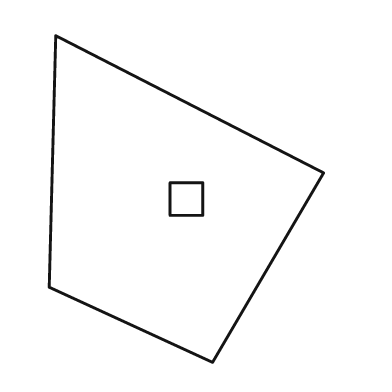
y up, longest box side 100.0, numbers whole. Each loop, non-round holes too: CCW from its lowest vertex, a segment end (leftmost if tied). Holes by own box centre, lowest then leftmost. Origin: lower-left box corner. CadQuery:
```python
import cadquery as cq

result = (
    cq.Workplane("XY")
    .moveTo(50.0, 0.0)
    .lineTo(84.0, 58.0)
    .lineTo(2.0, 100.0)
    .lineTo(0.0, 23.0)
    .close()
    .moveTo(37.0, 45.0)
    .lineTo(47.0, 45.0)
    .lineTo(47.0, 55.0)
    .lineTo(37.0, 55.0)
    .close()
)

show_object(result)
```